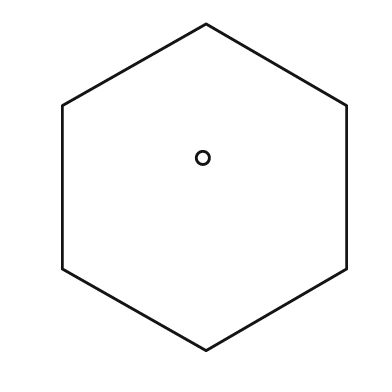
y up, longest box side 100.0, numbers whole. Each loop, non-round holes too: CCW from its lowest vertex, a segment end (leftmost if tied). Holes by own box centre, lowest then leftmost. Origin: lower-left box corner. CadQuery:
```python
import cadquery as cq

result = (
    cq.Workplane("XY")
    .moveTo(44.0, 0.0)
    .lineTo(87.0, 25.0)
    .lineTo(87.0, 75.0)
    .lineTo(44.0, 100.0)
    .lineTo(0.0, 75.0)
    .lineTo(0.0, 25.0)
    .close()
    .moveTo(43.0, 59.0)
    .circle(2.0)
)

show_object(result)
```